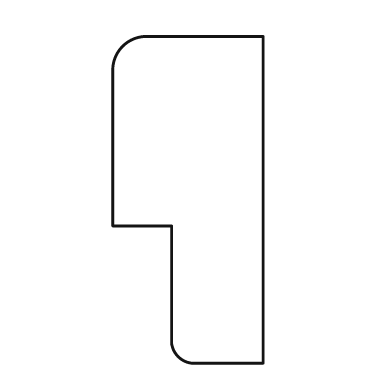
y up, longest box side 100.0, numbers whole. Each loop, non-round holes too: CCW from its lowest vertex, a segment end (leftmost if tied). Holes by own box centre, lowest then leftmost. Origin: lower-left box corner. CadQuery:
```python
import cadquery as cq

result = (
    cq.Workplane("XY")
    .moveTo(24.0, 0.0)
    .lineTo(46.0, 0.0)
    .lineTo(46.0, 100.0)
    .lineTo(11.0, 100.0)
    .threePointArc((3.0, 97.0), (0.0, 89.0))
    .lineTo(0.0, 42.0)
    .lineTo(18.0, 42.0)
    .lineTo(18.0, 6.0)
    .threePointArc((20.0, 2.0), (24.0, 0.0))
    .close()
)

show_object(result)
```